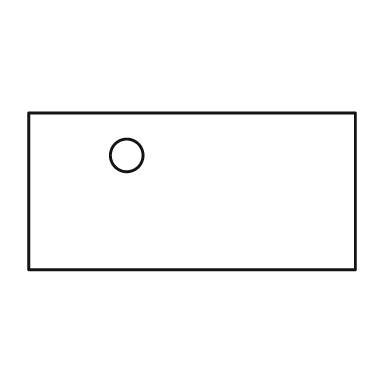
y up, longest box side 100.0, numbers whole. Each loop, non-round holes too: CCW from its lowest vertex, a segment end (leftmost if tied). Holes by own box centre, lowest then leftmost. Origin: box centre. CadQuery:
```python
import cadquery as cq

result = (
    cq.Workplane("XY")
    .moveTo(-50.0, -24.0)
    .lineTo(50.0, -24.0)
    .lineTo(50.0, 24.0)
    .lineTo(-50.0, 24.0)
    .close()
    .moveTo(-20.0, 11.0)
    .circle(5.0)
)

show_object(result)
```